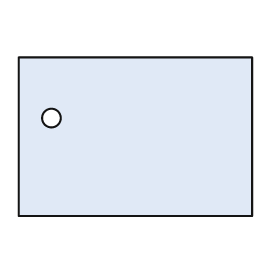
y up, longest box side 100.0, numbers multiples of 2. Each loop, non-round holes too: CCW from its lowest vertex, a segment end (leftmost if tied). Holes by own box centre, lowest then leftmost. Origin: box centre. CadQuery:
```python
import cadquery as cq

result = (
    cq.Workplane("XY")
    .moveTo(-50.0, -34.0)
    .lineTo(50.0, -34.0)
    .lineTo(50.0, 34.0)
    .lineTo(-50.0, 34.0)
    .close()
    .moveTo(-36.0, 8.0)
    .circle(4.0)
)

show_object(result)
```